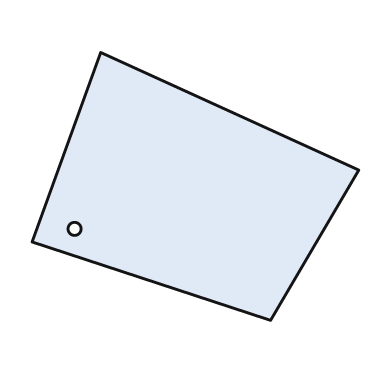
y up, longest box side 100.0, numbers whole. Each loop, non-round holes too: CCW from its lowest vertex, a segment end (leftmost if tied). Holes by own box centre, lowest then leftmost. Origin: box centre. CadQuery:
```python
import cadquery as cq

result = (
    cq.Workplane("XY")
    .moveTo(23.0, -41.0)
    .lineTo(50.0, 5.0)
    .lineTo(-29.0, 41.0)
    .lineTo(-50.0, -17.0)
    .close()
    .moveTo(-37.0, -13.0)
    .circle(2.0)
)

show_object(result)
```